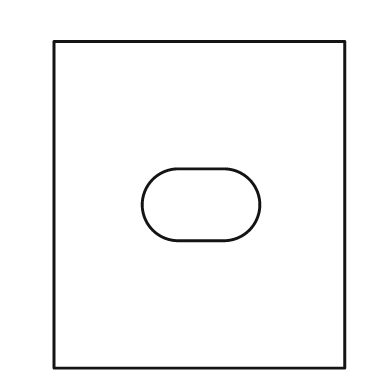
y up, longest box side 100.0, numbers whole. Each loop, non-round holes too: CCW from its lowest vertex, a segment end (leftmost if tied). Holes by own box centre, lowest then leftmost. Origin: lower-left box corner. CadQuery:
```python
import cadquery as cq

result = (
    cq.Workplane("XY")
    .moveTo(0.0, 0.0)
    .lineTo(89.0, 0.0)
    .lineTo(89.0, 100.0)
    .lineTo(0.0, 100.0)
    .close()
    .moveTo(38.0, 39.0)
    .lineTo(52.0, 39.0)
    .threePointArc((63.0, 50.0), (52.0, 61.0))
    .lineTo(38.0, 61.0)
    .threePointArc((27.0, 50.0), (38.0, 39.0))
    .close()
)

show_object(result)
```